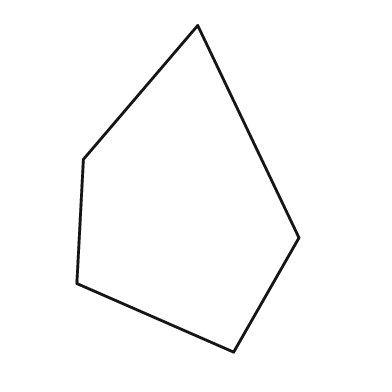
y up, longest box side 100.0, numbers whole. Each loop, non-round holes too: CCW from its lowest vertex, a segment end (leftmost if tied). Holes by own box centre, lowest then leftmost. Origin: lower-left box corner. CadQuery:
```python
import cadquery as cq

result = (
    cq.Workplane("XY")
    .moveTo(48.0, 0.0)
    .lineTo(68.0, 35.0)
    .lineTo(37.0, 100.0)
    .lineTo(2.0, 59.0)
    .lineTo(0.0, 21.0)
    .close()
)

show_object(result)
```